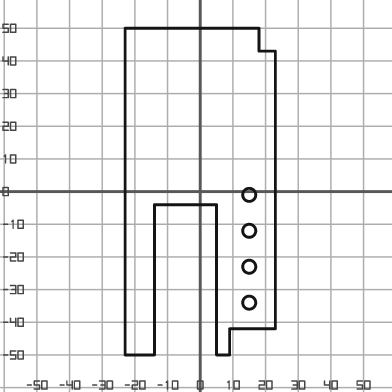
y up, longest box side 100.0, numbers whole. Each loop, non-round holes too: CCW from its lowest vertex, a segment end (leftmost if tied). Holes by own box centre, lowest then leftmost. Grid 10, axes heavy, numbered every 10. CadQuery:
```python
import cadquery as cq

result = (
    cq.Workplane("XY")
    .moveTo(-23.0, -50.0)
    .lineTo(-14.0, -50.0)
    .lineTo(-14.0, -4.0)
    .lineTo(5.0, -4.0)
    .lineTo(5.0, -50.0)
    .lineTo(9.0, -50.0)
    .lineTo(9.0, -42.0)
    .lineTo(23.0, -42.0)
    .lineTo(23.0, 43.0)
    .lineTo(18.0, 43.0)
    .lineTo(18.0, 50.0)
    .lineTo(-23.0, 50.0)
    .close()
    .moveTo(15.0, -34.0)
    .circle(2.0)
    .moveTo(15.0, -23.0)
    .circle(2.0)
    .moveTo(15.0, -12.0)
    .circle(2.0)
    .moveTo(15.0, -1.0)
    .circle(2.0)
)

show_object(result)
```